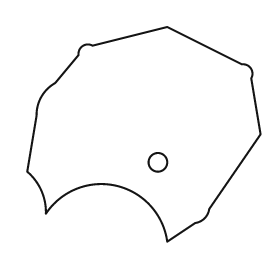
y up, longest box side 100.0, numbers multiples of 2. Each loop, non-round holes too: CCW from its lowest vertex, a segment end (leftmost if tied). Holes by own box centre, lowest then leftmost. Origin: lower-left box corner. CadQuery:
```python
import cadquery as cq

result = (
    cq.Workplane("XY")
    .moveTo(60.0, 0.0)
    .lineTo(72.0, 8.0)
    .threePointArc((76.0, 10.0), (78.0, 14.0))
    .lineTo(100.0, 46.0)
    .lineTo(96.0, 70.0)
    .threePointArc((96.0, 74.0), (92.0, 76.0))
    .lineTo(60.0, 92.0)
    .lineTo(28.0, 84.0)
    .threePointArc((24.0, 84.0), (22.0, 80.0))
    .lineTo(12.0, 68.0)
    .threePointArc((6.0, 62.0), (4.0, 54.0))
    .lineTo(0.0, 30.0)
    .threePointArc((6.0, 22.0), (8.0, 12.0))
    .threePointArc((38.0, 24.0), (60.0, 0.0))
    .close()
    .moveTo(56.0, 34.0)
    .circle(4.0)
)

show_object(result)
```